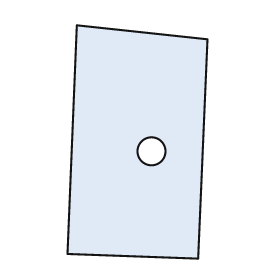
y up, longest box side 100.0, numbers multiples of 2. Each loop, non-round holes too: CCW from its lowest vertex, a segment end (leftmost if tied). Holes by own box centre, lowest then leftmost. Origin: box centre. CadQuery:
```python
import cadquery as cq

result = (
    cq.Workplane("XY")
    .moveTo(26.0, -50.0)
    .lineTo(30.0, 44.0)
    .lineTo(-26.0, 50.0)
    .lineTo(-30.0, -48.0)
    .close()
    .moveTo(6.0, -4.0)
    .circle(6.0)
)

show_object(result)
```